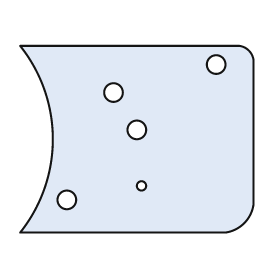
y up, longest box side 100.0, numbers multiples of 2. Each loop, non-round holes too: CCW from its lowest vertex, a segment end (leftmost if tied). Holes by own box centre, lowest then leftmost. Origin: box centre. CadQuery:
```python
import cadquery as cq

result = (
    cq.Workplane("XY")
    .moveTo(-50.0, -40.0)
    .lineTo(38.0, -40.0)
    .threePointArc((46.0, -36.0), (50.0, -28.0))
    .lineTo(50.0, 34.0)
    .threePointArc((48.0, 38.0), (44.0, 40.0))
    .lineTo(-50.0, 40.0)
    .threePointArc((-36.0, 0.0), (-50.0, -40.0))
    .close()
    .moveTo(-30.0, -26.0)
    .circle(4.0)
    .moveTo(2.0, -20.0)
    .circle(2.0)
    .moveTo(0.0, 4.0)
    .circle(4.0)
    .moveTo(-10.0, 20.0)
    .circle(4.0)
    .moveTo(34.0, 32.0)
    .circle(4.0)
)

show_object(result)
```